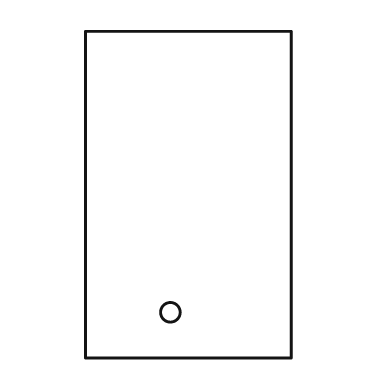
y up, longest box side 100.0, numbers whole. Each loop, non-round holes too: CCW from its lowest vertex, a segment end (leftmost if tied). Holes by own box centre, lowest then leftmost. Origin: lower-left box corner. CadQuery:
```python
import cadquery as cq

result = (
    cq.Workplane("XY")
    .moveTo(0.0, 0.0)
    .lineTo(63.0, 0.0)
    .lineTo(63.0, 100.0)
    .lineTo(0.0, 100.0)
    .close()
    .moveTo(26.0, 14.0)
    .circle(3.0)
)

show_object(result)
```